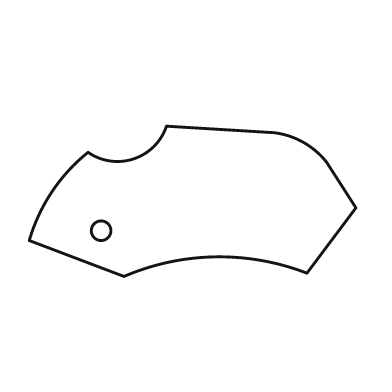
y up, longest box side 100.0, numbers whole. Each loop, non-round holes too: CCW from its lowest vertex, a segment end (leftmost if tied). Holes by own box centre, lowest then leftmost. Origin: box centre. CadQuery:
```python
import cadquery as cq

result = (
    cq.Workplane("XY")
    .moveTo(-21.0, -23.0)
    .threePointArc((7.0, -17.0), (35.0, -22.0))
    .lineTo(50.0, -2.0)
    .lineTo(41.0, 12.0)
    .threePointArc((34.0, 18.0), (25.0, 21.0))
    .lineTo(-8.0, 23.0)
    .threePointArc((-18.0, 13.0), (-32.0, 15.0))
    .threePointArc((-43.0, 3.0), (-50.0, -12.0))
    .close()
    .moveTo(-28.0, -9.0)
    .circle(3.0)
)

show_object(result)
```